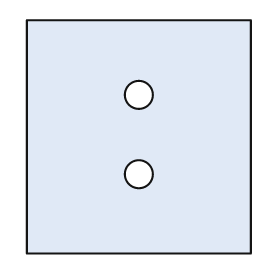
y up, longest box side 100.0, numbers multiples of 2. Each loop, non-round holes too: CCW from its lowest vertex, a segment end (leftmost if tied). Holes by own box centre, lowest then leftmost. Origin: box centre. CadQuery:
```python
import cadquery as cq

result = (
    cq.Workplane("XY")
    .moveTo(-48.0, -50.0)
    .lineTo(48.0, -50.0)
    .lineTo(48.0, 50.0)
    .lineTo(-48.0, 50.0)
    .close()
    .moveTo(0.0, -16.0)
    .circle(6.0)
    .moveTo(0.0, 18.0)
    .circle(6.0)
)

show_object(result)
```